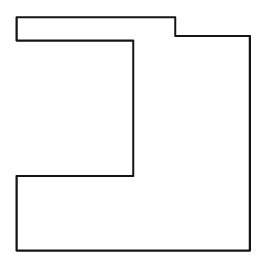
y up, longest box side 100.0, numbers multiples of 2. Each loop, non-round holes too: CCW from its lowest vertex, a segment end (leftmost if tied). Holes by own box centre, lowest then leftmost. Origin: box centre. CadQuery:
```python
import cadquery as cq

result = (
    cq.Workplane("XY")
    .moveTo(-50.0, -50.0)
    .lineTo(50.0, -50.0)
    .lineTo(50.0, 42.0)
    .lineTo(18.0, 42.0)
    .lineTo(18.0, 50.0)
    .lineTo(-50.0, 50.0)
    .lineTo(-50.0, 40.0)
    .lineTo(0.0, 40.0)
    .lineTo(0.0, -18.0)
    .lineTo(-50.0, -18.0)
    .close()
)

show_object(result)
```